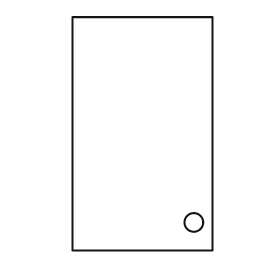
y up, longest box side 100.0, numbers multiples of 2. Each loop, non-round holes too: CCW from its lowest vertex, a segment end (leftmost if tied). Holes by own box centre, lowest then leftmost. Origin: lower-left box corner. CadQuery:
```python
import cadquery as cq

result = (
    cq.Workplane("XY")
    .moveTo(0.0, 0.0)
    .lineTo(60.0, 0.0)
    .lineTo(60.0, 100.0)
    .lineTo(0.0, 100.0)
    .close()
    .moveTo(52.0, 12.0)
    .circle(4.0)
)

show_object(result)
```